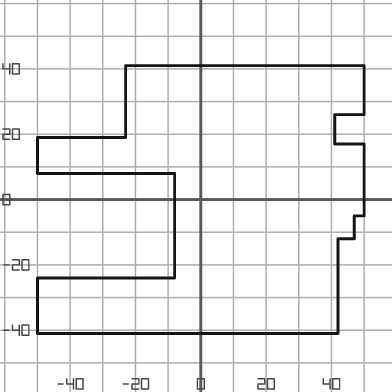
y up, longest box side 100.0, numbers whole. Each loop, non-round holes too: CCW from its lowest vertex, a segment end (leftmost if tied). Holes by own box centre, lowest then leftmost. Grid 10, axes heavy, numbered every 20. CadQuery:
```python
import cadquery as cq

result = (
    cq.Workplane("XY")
    .moveTo(-50.0, -41.0)
    .lineTo(42.0, -41.0)
    .lineTo(42.0, -12.0)
    .lineTo(47.0, -12.0)
    .lineTo(47.0, -5.0)
    .lineTo(50.0, -5.0)
    .lineTo(50.0, 17.0)
    .lineTo(41.0, 17.0)
    .lineTo(41.0, 26.0)
    .lineTo(50.0, 26.0)
    .lineTo(50.0, 41.0)
    .lineTo(-23.0, 41.0)
    .lineTo(-23.0, 19.0)
    .lineTo(-50.0, 19.0)
    .lineTo(-50.0, 8.0)
    .lineTo(-8.0, 8.0)
    .lineTo(-8.0, -24.0)
    .lineTo(-50.0, -24.0)
    .close()
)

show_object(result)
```